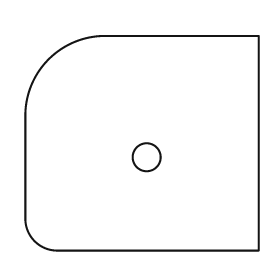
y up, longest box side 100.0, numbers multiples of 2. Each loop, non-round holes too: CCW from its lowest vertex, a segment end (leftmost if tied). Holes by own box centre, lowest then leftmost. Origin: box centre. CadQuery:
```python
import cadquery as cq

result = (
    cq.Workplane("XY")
    .moveTo(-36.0, -46.0)
    .lineTo(50.0, -46.0)
    .lineTo(50.0, 46.0)
    .lineTo(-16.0, 46.0)
    .threePointArc((-40.0, 36.0), (-50.0, 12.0))
    .lineTo(-50.0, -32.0)
    .threePointArc((-46.0, -42.0), (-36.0, -46.0))
    .close()
    .moveTo(2.0, -6.0)
    .circle(6.0)
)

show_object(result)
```